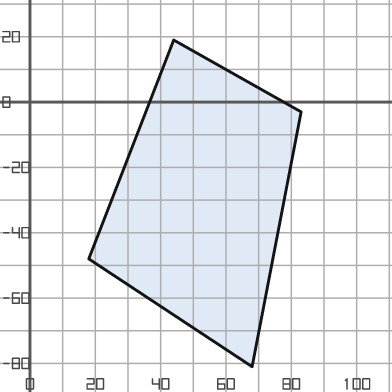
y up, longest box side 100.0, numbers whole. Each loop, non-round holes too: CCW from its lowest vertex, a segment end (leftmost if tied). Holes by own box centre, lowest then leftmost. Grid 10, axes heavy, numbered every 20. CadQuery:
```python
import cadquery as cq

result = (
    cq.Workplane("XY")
    .moveTo(68.0, -81.0)
    .lineTo(83.0, -3.0)
    .lineTo(44.0, 19.0)
    .lineTo(18.0, -48.0)
    .close()
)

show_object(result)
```